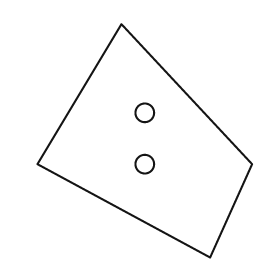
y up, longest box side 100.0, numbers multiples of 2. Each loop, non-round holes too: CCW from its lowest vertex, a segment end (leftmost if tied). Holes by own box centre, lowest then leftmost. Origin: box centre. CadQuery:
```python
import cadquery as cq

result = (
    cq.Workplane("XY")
    .moveTo(28.0, -50.0)
    .lineTo(46.0, -10.0)
    .lineTo(-10.0, 50.0)
    .lineTo(-46.0, -10.0)
    .close()
    .moveTo(0.0, -10.0)
    .circle(4.0)
    .moveTo(0.0, 12.0)
    .circle(4.0)
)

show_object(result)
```